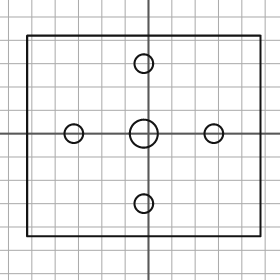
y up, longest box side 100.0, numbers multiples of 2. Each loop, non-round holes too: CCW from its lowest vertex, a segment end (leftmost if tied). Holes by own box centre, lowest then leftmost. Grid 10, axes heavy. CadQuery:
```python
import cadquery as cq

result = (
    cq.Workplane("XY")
    .moveTo(-52.0, -44.0)
    .lineTo(48.0, -44.0)
    .lineTo(48.0, 42.0)
    .lineTo(-52.0, 42.0)
    .close()
    .moveTo(-2.0, -30.0)
    .circle(4.0)
    .moveTo(-32.0, 0.0)
    .circle(4.0)
    .moveTo(-2.0, 0.0)
    .circle(6.0)
    .moveTo(28.0, 0.0)
    .circle(4.0)
    .moveTo(-2.0, 30.0)
    .circle(4.0)
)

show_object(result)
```